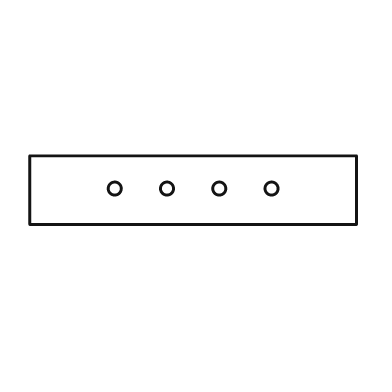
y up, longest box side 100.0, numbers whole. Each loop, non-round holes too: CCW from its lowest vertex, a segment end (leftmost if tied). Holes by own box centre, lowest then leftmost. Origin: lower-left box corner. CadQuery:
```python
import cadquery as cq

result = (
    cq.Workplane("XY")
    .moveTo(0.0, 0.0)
    .lineTo(100.0, 0.0)
    .lineTo(100.0, 21.0)
    .lineTo(0.0, 21.0)
    .close()
    .moveTo(26.0, 11.0)
    .circle(2.0)
    .moveTo(42.0, 11.0)
    .circle(2.0)
    .moveTo(58.0, 11.0)
    .circle(2.0)
    .moveTo(74.0, 11.0)
    .circle(2.0)
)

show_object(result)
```